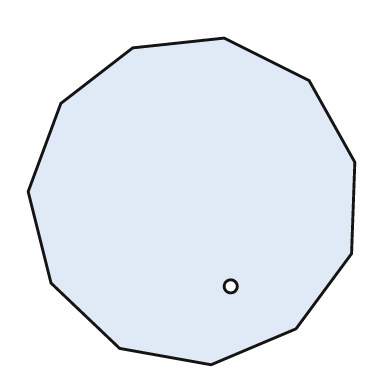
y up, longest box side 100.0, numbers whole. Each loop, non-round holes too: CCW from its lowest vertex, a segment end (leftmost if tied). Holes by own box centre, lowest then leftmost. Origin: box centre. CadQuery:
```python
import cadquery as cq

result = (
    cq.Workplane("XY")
    .moveTo(6.0, -50.0)
    .lineTo(32.0, -39.0)
    .lineTo(49.0, -16.0)
    .lineTo(50.0, 12.0)
    .lineTo(36.0, 37.0)
    .lineTo(10.0, 50.0)
    .lineTo(-18.0, 47.0)
    .lineTo(-40.0, 30.0)
    .lineTo(-50.0, 3.0)
    .lineTo(-43.0, -25.0)
    .lineTo(-22.0, -45.0)
    .close()
    .moveTo(12.0, -26.0)
    .circle(2.0)
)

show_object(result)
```